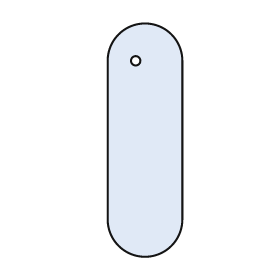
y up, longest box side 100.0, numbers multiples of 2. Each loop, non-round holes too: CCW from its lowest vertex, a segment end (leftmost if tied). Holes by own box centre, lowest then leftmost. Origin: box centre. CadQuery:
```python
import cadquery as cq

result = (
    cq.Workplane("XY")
    .moveTo(-16.0, -34.0)
    .threePointArc((0.0, -50.0), (16.0, -34.0))
    .lineTo(16.0, 34.0)
    .threePointArc((0.0, 50.0), (-16.0, 34.0))
    .close()
    .moveTo(-4.0, 34.0)
    .circle(2.0)
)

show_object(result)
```